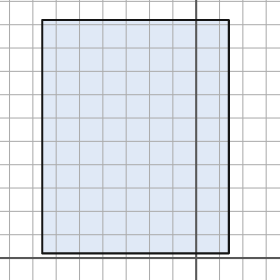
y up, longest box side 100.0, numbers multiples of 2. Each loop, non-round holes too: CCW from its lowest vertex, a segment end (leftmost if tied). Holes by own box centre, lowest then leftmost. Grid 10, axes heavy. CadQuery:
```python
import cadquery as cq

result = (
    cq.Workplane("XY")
    .moveTo(-66.0, 2.0)
    .lineTo(14.0, 2.0)
    .lineTo(14.0, 102.0)
    .lineTo(-66.0, 102.0)
    .close()
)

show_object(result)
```